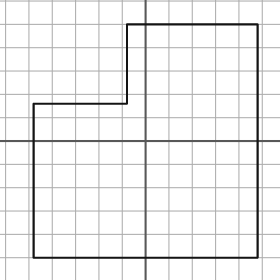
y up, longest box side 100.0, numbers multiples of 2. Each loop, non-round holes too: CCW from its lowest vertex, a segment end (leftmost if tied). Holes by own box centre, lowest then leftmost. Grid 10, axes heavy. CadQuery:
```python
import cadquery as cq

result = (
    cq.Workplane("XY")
    .moveTo(-48.0, -50.0)
    .lineTo(48.0, -50.0)
    .lineTo(48.0, 50.0)
    .lineTo(-8.0, 50.0)
    .lineTo(-8.0, 16.0)
    .lineTo(-48.0, 16.0)
    .close()
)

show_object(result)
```